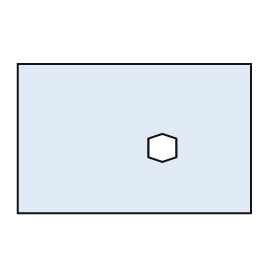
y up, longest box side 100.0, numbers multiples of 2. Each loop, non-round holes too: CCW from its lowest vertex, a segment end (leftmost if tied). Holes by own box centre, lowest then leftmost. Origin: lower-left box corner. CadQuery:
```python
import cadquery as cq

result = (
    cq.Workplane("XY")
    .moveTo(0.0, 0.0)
    .lineTo(100.0, 0.0)
    .lineTo(100.0, 64.0)
    .lineTo(0.0, 64.0)
    .close()
    .moveTo(62.0, 22.0)
    .lineTo(68.0, 24.0)
    .lineTo(68.0, 32.0)
    .lineTo(62.0, 34.0)
    .lineTo(56.0, 32.0)
    .lineTo(56.0, 24.0)
    .close()
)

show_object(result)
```